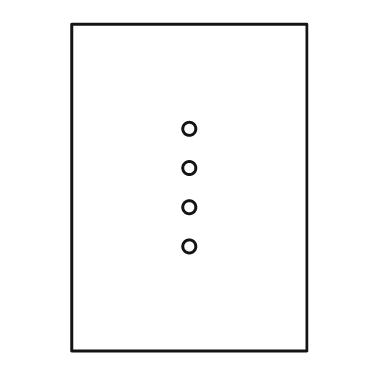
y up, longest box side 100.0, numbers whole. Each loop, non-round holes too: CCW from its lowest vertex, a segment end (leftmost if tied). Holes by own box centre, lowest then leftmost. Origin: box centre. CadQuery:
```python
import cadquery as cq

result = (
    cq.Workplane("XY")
    .moveTo(-36.0, -50.0)
    .lineTo(36.0, -50.0)
    .lineTo(36.0, 50.0)
    .lineTo(-36.0, 50.0)
    .close()
    .moveTo(0.0, -18.0)
    .circle(2.0)
    .moveTo(0.0, -6.0)
    .circle(2.0)
    .moveTo(0.0, 6.0)
    .circle(2.0)
    .moveTo(0.0, 18.0)
    .circle(2.0)
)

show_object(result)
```